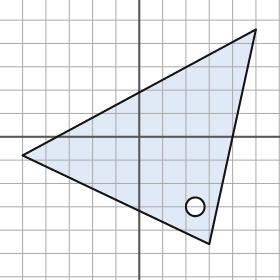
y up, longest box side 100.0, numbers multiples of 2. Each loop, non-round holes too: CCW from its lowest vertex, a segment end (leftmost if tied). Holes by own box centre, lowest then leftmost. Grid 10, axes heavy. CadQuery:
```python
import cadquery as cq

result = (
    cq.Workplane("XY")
    .moveTo(30.0, -46.0)
    .lineTo(50.0, 46.0)
    .lineTo(-50.0, -8.0)
    .close()
    .moveTo(24.0, -30.0)
    .circle(4.0)
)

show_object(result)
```